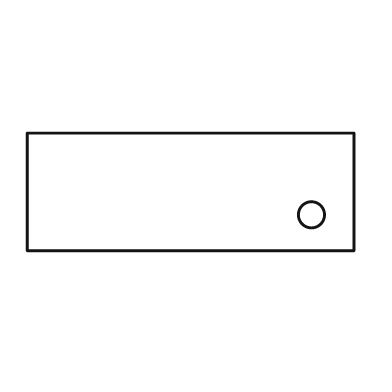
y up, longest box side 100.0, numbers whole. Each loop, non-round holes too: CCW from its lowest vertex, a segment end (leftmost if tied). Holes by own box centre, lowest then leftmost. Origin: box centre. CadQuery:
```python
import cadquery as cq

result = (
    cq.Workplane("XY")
    .moveTo(-50.0, -18.0)
    .lineTo(50.0, -18.0)
    .lineTo(50.0, 18.0)
    .lineTo(-50.0, 18.0)
    .close()
    .moveTo(37.0, -7.0)
    .circle(4.0)
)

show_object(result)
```